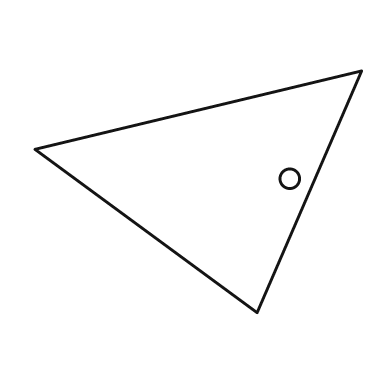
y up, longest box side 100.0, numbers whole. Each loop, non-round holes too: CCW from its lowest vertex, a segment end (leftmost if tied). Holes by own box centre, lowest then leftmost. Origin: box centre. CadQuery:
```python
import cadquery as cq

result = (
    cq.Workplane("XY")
    .moveTo(18.0, -37.0)
    .lineTo(50.0, 37.0)
    .lineTo(-50.0, 13.0)
    .close()
    .moveTo(28.0, 4.0)
    .circle(3.0)
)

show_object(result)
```